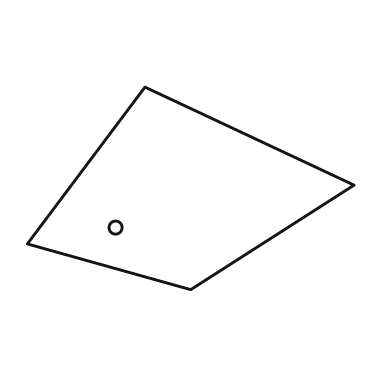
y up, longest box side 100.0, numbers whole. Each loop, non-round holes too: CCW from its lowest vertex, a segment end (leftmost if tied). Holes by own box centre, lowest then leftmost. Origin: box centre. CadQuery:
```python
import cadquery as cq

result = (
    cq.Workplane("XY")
    .moveTo(0.0, -31.0)
    .lineTo(50.0, 1.0)
    .lineTo(-14.0, 31.0)
    .lineTo(-50.0, -17.0)
    .close()
    .moveTo(-23.0, -12.0)
    .circle(2.0)
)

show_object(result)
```